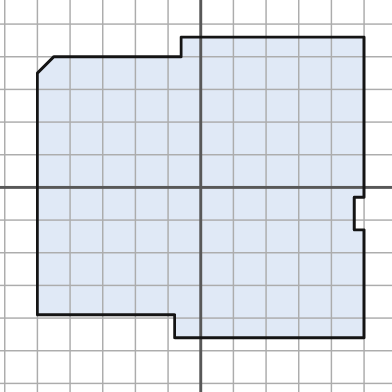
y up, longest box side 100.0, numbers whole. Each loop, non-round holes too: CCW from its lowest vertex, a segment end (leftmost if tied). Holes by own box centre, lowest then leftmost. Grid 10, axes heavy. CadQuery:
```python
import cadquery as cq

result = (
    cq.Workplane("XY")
    .moveTo(-8.0, -46.0)
    .lineTo(50.0, -46.0)
    .lineTo(50.0, -13.0)
    .lineTo(47.0, -13.0)
    .lineTo(47.0, -3.0)
    .lineTo(50.0, -3.0)
    .lineTo(50.0, 46.0)
    .lineTo(-6.0, 46.0)
    .lineTo(-6.0, 40.0)
    .lineTo(-45.0, 40.0)
    .lineTo(-50.0, 35.0)
    .lineTo(-50.0, -39.0)
    .lineTo(-8.0, -39.0)
    .close()
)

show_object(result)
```